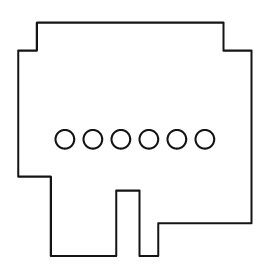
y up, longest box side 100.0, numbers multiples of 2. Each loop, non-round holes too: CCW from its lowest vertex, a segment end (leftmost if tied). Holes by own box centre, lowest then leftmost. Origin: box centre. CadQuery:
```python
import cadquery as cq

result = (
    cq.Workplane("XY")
    .moveTo(-36.0, -50.0)
    .lineTo(-8.0, -50.0)
    .lineTo(-8.0, -22.0)
    .lineTo(2.0, -22.0)
    .lineTo(2.0, -50.0)
    .lineTo(10.0, -50.0)
    .lineTo(10.0, -36.0)
    .lineTo(50.0, -36.0)
    .lineTo(50.0, 38.0)
    .lineTo(38.0, 38.0)
    .lineTo(38.0, 50.0)
    .lineTo(-42.0, 50.0)
    .lineTo(-42.0, 38.0)
    .lineTo(-50.0, 38.0)
    .lineTo(-50.0, -16.0)
    .lineTo(-36.0, -16.0)
    .close()
    .moveTo(-30.0, 0.0)
    .circle(4.0)
    .moveTo(-18.0, 0.0)
    .circle(4.0)
    .moveTo(-6.0, 0.0)
    .circle(4.0)
    .moveTo(6.0, 0.0)
    .circle(4.0)
    .moveTo(18.0, 0.0)
    .circle(4.0)
    .moveTo(30.0, 0.0)
    .circle(4.0)
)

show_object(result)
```